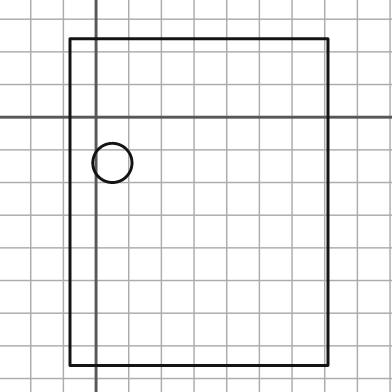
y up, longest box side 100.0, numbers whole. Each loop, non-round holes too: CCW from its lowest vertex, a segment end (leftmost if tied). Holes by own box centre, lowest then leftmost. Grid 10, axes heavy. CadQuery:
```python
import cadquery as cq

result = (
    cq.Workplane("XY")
    .moveTo(-8.0, -76.0)
    .lineTo(71.0, -76.0)
    .lineTo(71.0, 24.0)
    .lineTo(-8.0, 24.0)
    .close()
    .moveTo(5.0, -14.0)
    .circle(6.0)
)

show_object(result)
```